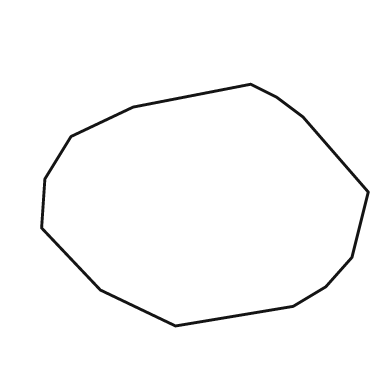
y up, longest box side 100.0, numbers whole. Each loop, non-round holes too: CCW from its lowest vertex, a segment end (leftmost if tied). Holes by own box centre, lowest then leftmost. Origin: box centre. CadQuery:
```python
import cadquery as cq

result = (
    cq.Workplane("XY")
    .moveTo(-9.0, -37.0)
    .lineTo(27.0, -31.0)
    .lineTo(37.0, -25.0)
    .lineTo(45.0, -16.0)
    .lineTo(50.0, 4.0)
    .lineTo(30.0, 27.0)
    .lineTo(22.0, 33.0)
    .lineTo(14.0, 37.0)
    .lineTo(-22.0, 30.0)
    .lineTo(-41.0, 21.0)
    .lineTo(-49.0, 8.0)
    .lineTo(-50.0, -7.0)
    .lineTo(-32.0, -26.0)
    .close()
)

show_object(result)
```